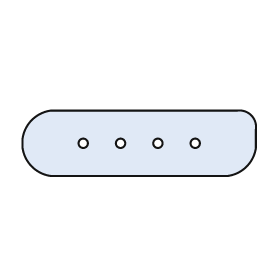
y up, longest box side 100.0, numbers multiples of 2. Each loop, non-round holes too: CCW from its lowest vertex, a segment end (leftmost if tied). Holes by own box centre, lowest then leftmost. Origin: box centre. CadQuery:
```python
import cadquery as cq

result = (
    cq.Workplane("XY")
    .moveTo(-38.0, -14.0)
    .lineTo(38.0, -14.0)
    .threePointArc((46.0, -10.0), (50.0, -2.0))
    .lineTo(50.0, 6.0)
    .threePointArc((48.0, 12.0), (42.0, 14.0))
    .lineTo(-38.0, 14.0)
    .threePointArc((-46.0, 10.0), (-50.0, 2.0))
    .lineTo(-50.0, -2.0)
    .threePointArc((-46.0, -10.0), (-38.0, -14.0))
    .close()
    .moveTo(-24.0, 0.0)
    .circle(2.0)
    .moveTo(-8.0, 0.0)
    .circle(2.0)
    .moveTo(8.0, 0.0)
    .circle(2.0)
    .moveTo(24.0, 0.0)
    .circle(2.0)
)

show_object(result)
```